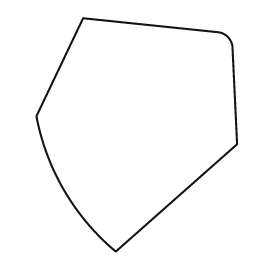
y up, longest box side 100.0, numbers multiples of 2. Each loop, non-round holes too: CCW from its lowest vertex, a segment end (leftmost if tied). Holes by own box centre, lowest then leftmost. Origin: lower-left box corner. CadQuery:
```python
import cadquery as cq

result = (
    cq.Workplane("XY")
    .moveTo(34.0, 0.0)
    .lineTo(86.0, 46.0)
    .lineTo(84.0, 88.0)
    .threePointArc((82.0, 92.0), (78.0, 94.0))
    .lineTo(20.0, 100.0)
    .lineTo(0.0, 58.0)
    .threePointArc((12.0, 26.0), (34.0, 0.0))
    .close()
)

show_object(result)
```